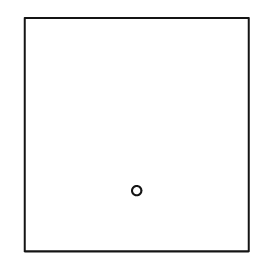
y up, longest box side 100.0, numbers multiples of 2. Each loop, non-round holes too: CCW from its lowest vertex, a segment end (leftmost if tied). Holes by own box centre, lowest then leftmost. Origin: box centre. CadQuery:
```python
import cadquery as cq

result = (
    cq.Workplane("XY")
    .moveTo(-48.0, -50.0)
    .lineTo(48.0, -50.0)
    .lineTo(48.0, 50.0)
    .lineTo(-48.0, 50.0)
    .close()
    .moveTo(0.0, -24.0)
    .circle(2.0)
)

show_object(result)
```